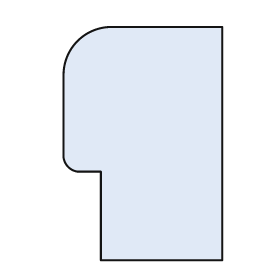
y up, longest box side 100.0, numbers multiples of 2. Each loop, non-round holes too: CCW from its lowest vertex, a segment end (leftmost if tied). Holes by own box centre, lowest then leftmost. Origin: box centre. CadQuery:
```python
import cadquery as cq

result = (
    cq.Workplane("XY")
    .moveTo(-18.0, -50.0)
    .lineTo(34.0, -50.0)
    .lineTo(34.0, 50.0)
    .lineTo(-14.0, 50.0)
    .threePointArc((-28.0, 44.0), (-34.0, 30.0))
    .lineTo(-34.0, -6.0)
    .threePointArc((-32.0, -10.0), (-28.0, -12.0))
    .lineTo(-18.0, -12.0)
    .close()
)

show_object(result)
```